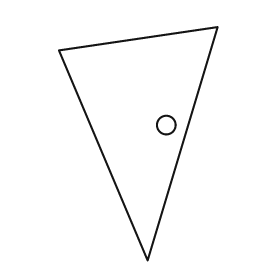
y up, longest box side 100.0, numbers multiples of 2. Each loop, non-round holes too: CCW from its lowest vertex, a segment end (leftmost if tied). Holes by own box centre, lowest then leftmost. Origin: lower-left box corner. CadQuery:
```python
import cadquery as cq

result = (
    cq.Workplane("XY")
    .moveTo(38.0, 0.0)
    .lineTo(68.0, 100.0)
    .lineTo(0.0, 90.0)
    .close()
    .moveTo(46.0, 58.0)
    .circle(4.0)
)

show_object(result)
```